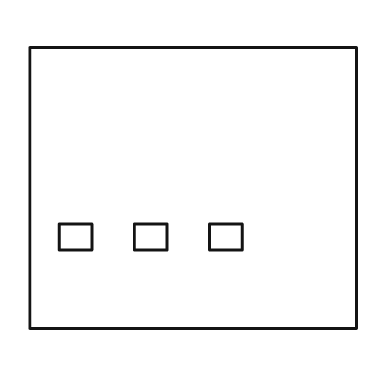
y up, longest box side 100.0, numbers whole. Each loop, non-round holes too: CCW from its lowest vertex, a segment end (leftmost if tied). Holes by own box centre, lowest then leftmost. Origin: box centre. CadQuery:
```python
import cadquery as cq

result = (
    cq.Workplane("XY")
    .moveTo(-50.0, -43.0)
    .lineTo(50.0, -43.0)
    .lineTo(50.0, 43.0)
    .lineTo(-50.0, 43.0)
    .close()
    .moveTo(-41.0, -19.0)
    .lineTo(-31.0, -19.0)
    .lineTo(-31.0, -11.0)
    .lineTo(-41.0, -11.0)
    .close()
    .moveTo(-18.0, -19.0)
    .lineTo(-8.0, -19.0)
    .lineTo(-8.0, -11.0)
    .lineTo(-18.0, -11.0)
    .close()
    .moveTo(5.0, -19.0)
    .lineTo(15.0, -19.0)
    .lineTo(15.0, -11.0)
    .lineTo(5.0, -11.0)
    .close()
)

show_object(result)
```